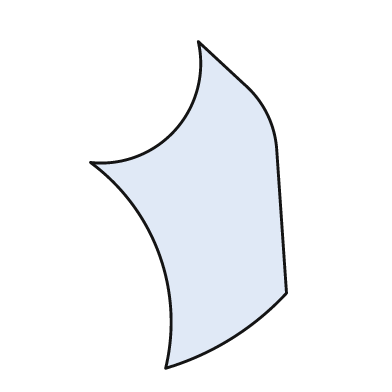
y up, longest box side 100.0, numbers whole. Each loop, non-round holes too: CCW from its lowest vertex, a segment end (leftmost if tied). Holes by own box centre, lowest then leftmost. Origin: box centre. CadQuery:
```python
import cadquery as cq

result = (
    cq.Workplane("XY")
    .moveTo(-7.0, -50.0)
    .threePointArc((13.0, -41.0), (30.0, -27.0))
    .lineTo(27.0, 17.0)
    .threePointArc((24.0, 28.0), (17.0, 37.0))
    .lineTo(3.0, 50.0)
    .threePointArc((-4.0, 23.0), (-30.0, 13.0))
    .threePointArc((-9.0, -15.0), (-7.0, -50.0))
    .close()
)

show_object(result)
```